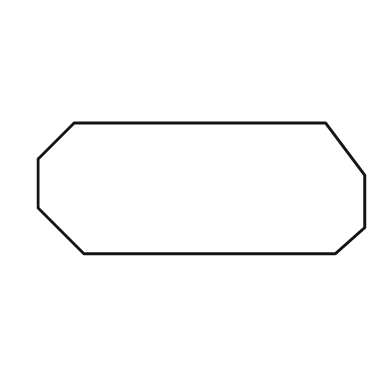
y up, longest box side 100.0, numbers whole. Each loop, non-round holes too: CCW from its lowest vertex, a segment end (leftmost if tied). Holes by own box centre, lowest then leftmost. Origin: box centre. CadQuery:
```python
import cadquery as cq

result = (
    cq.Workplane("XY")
    .moveTo(-36.0, -20.0)
    .lineTo(41.0, -20.0)
    .lineTo(50.0, -12.0)
    .lineTo(50.0, 4.0)
    .lineTo(38.0, 20.0)
    .lineTo(-39.0, 20.0)
    .lineTo(-50.0, 9.0)
    .lineTo(-50.0, -6.0)
    .close()
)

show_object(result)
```